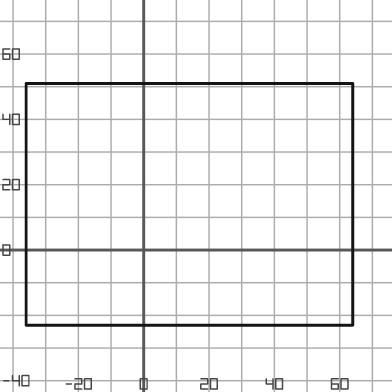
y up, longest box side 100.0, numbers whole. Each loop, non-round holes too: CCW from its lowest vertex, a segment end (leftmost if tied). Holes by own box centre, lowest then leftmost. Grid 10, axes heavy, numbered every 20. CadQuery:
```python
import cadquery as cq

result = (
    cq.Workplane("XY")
    .moveTo(-36.0, -23.0)
    .lineTo(64.0, -23.0)
    .lineTo(64.0, 51.0)
    .lineTo(-36.0, 51.0)
    .close()
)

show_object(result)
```